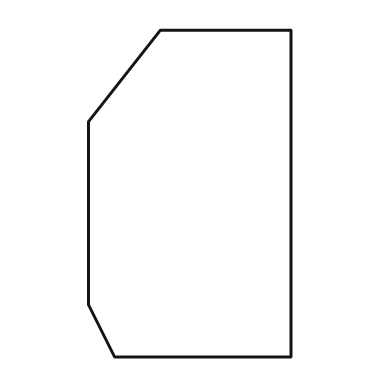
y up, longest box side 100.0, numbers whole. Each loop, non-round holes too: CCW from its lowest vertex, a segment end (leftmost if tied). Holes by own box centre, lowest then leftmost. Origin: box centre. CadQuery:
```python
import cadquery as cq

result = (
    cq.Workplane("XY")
    .moveTo(-23.0, -50.0)
    .lineTo(31.0, -50.0)
    .lineTo(31.0, 50.0)
    .lineTo(-9.0, 50.0)
    .lineTo(-31.0, 22.0)
    .lineTo(-31.0, -34.0)
    .close()
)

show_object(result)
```